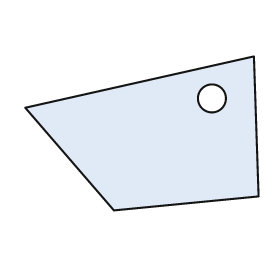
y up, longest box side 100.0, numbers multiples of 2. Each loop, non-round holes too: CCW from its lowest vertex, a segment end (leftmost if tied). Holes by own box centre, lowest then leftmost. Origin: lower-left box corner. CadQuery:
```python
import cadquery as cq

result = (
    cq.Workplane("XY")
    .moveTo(38.0, 0.0)
    .lineTo(100.0, 6.0)
    .lineTo(98.0, 66.0)
    .lineTo(0.0, 44.0)
    .close()
    .moveTo(80.0, 48.0)
    .circle(6.0)
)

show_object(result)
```